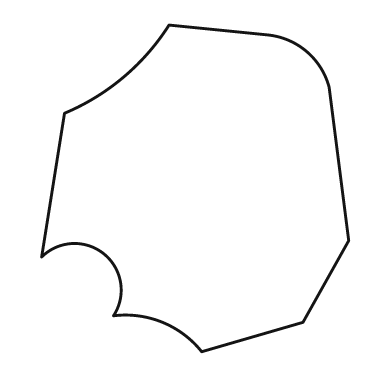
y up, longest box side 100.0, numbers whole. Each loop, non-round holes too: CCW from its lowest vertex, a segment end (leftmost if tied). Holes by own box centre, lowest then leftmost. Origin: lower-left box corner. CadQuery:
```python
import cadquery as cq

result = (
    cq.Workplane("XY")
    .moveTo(49.0, 0.0)
    .lineTo(80.0, 9.0)
    .lineTo(94.0, 34.0)
    .lineTo(88.0, 81.0)
    .threePointArc((81.0, 92.0), (69.0, 97.0))
    .lineTo(39.0, 100.0)
    .threePointArc((25.0, 84.0), (7.0, 73.0))
    .lineTo(0.0, 29.0)
    .threePointArc((19.0, 30.0), (22.0, 11.0))
    .threePointArc((37.0, 9.0), (49.0, 0.0))
    .close()
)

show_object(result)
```